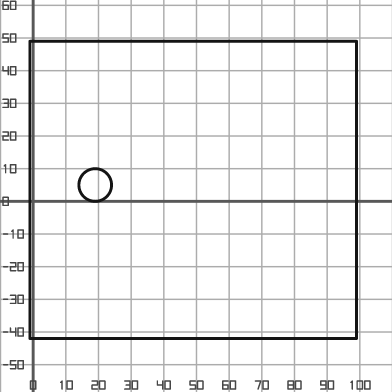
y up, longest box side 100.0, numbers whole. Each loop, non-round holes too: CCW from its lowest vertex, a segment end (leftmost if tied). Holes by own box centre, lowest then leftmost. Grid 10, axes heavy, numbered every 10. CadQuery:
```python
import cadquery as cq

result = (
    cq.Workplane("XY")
    .moveTo(-1.0, -42.0)
    .lineTo(99.0, -42.0)
    .lineTo(99.0, 49.0)
    .lineTo(-1.0, 49.0)
    .close()
    .moveTo(19.0, 5.0)
    .circle(5.0)
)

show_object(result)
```